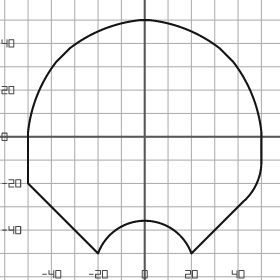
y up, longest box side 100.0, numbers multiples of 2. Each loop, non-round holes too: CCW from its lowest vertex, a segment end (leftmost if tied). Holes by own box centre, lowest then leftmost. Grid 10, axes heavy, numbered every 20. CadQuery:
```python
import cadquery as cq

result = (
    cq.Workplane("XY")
    .moveTo(-20.0, -50.0)
    .threePointArc((0.0, -36.0), (20.0, -50.0))
    .lineTo(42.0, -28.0)
    .threePointArc((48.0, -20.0), (50.0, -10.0))
    .lineTo(50.0, 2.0)
    .threePointArc((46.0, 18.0), (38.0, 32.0))
    .lineTo(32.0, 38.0)
    .threePointArc((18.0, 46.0), (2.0, 50.0))
    .lineTo(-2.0, 50.0)
    .threePointArc((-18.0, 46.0), (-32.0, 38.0))
    .lineTo(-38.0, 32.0)
    .threePointArc((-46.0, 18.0), (-50.0, 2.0))
    .lineTo(-50.0, -20.0)
    .close()
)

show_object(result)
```